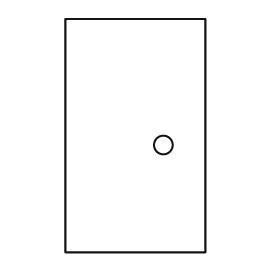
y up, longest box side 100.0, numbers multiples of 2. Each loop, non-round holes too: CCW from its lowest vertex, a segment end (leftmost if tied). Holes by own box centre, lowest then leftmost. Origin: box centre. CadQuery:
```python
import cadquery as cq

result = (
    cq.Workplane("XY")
    .moveTo(-30.0, -50.0)
    .lineTo(30.0, -50.0)
    .lineTo(30.0, 50.0)
    .lineTo(-30.0, 50.0)
    .close()
    .moveTo(12.0, -4.0)
    .circle(4.0)
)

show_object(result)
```